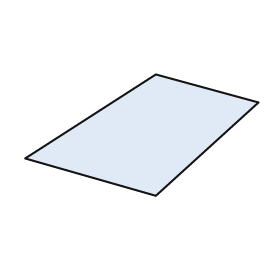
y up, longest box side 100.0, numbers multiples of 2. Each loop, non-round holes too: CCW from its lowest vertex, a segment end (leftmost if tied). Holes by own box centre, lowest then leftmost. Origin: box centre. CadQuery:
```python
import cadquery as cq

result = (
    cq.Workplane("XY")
    .moveTo(6.0, -26.0)
    .lineTo(50.0, 14.0)
    .lineTo(6.0, 26.0)
    .lineTo(-50.0, -10.0)
    .close()
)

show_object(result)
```